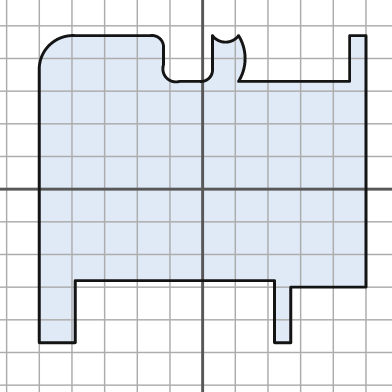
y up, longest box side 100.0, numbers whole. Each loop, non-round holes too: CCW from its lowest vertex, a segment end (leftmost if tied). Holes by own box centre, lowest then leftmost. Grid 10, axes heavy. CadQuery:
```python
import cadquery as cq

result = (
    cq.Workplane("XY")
    .moveTo(-50.0, -47.0)
    .lineTo(-39.0, -47.0)
    .lineTo(-39.0, -28.0)
    .lineTo(22.0, -28.0)
    .lineTo(22.0, -47.0)
    .lineTo(27.0, -47.0)
    .lineTo(27.0, -30.0)
    .lineTo(50.0, -30.0)
    .lineTo(50.0, 47.0)
    .lineTo(45.0, 47.0)
    .lineTo(45.0, 33.0)
    .lineTo(11.0, 33.0)
    .threePointArc((13.0, 40.0), (11.0, 47.0))
    .threePointArc((7.0, 45.0), (3.0, 47.0))
    .lineTo(3.0, 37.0)
    .threePointArc((2.0, 34.0), (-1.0, 33.0))
    .lineTo(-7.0, 33.0)
    .threePointArc((-11.0, 34.0), (-12.0, 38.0))
    .lineTo(-12.0, 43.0)
    .threePointArc((-13.0, 46.0), (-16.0, 47.0))
    .lineTo(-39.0, 47.0)
    .threePointArc((-47.0, 44.0), (-50.0, 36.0))
    .close()
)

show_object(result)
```